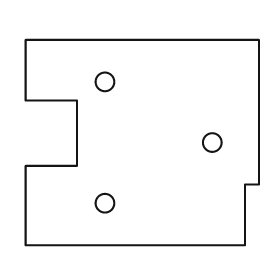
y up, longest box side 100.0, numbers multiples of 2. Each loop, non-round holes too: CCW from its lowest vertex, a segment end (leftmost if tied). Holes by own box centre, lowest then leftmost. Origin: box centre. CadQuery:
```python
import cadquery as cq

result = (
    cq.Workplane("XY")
    .moveTo(-50.0, -44.0)
    .lineTo(44.0, -44.0)
    .lineTo(44.0, -18.0)
    .lineTo(50.0, -18.0)
    .lineTo(50.0, 44.0)
    .lineTo(-50.0, 44.0)
    .lineTo(-50.0, 18.0)
    .lineTo(-28.0, 18.0)
    .lineTo(-28.0, -10.0)
    .lineTo(-50.0, -10.0)
    .close()
    .moveTo(-16.0, -26.0)
    .circle(4.0)
    .moveTo(30.0, 0.0)
    .circle(4.0)
    .moveTo(-16.0, 26.0)
    .circle(4.0)
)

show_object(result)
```